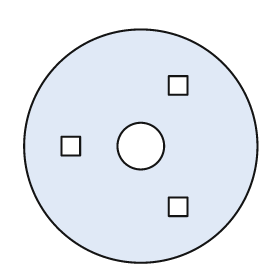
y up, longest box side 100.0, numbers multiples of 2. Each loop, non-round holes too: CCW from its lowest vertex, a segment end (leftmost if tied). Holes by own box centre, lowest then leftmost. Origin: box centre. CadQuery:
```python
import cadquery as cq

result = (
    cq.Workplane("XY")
    .moveTo(0.0, 0.0)
    .circle(50.0)
    .moveTo(12.0, -30.0)
    .lineTo(20.0, -30.0)
    .lineTo(20.0, -22.0)
    .lineTo(12.0, -22.0)
    .close()
    .moveTo(-34.0, -4.0)
    .lineTo(-26.0, -4.0)
    .lineTo(-26.0, 4.0)
    .lineTo(-34.0, 4.0)
    .close()
    .moveTo(0.0, 0.0)
    .circle(10.0)
    .moveTo(12.0, 22.0)
    .lineTo(20.0, 22.0)
    .lineTo(20.0, 30.0)
    .lineTo(12.0, 30.0)
    .close()
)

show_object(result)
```